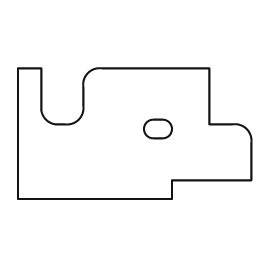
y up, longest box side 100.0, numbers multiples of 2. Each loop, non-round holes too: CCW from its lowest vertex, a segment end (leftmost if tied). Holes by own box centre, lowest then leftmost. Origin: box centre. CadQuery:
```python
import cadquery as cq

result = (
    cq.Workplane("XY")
    .moveTo(-50.0, -28.0)
    .lineTo(16.0, -28.0)
    .lineTo(16.0, -20.0)
    .lineTo(50.0, -20.0)
    .lineTo(50.0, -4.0)
    .threePointArc((48.0, 2.0), (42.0, 4.0))
    .lineTo(32.0, 4.0)
    .lineTo(32.0, 28.0)
    .lineTo(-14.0, 28.0)
    .threePointArc((-20.0, 26.0), (-22.0, 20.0))
    .lineTo(-22.0, 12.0)
    .threePointArc((-24.0, 6.0), (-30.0, 4.0))
    .lineTo(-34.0, 4.0)
    .threePointArc((-38.0, 6.0), (-40.0, 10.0))
    .lineTo(-40.0, 28.0)
    .lineTo(-50.0, 28.0)
    .close()
    .moveTo(8.0, -2.0)
    .lineTo(12.0, -2.0)
    .threePointArc((16.0, 2.0), (12.0, 6.0))
    .lineTo(8.0, 6.0)
    .threePointArc((4.0, 2.0), (8.0, -2.0))
    .close()
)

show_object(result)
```